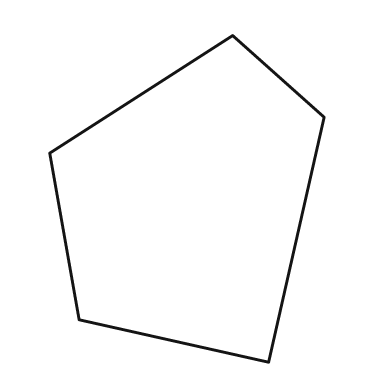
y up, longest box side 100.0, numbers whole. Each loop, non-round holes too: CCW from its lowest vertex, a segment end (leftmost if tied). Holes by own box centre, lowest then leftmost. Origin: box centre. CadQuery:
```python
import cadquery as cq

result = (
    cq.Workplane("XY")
    .moveTo(25.0, -50.0)
    .lineTo(42.0, 25.0)
    .lineTo(14.0, 50.0)
    .lineTo(-42.0, 14.0)
    .lineTo(-33.0, -37.0)
    .close()
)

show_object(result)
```